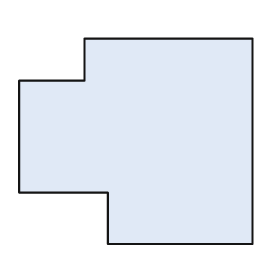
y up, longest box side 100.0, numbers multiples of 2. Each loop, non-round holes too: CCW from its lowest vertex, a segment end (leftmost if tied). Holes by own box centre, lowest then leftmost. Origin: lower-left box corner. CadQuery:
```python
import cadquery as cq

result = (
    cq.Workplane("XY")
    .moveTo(38.0, 0.0)
    .lineTo(100.0, 0.0)
    .lineTo(100.0, 88.0)
    .lineTo(28.0, 88.0)
    .lineTo(28.0, 70.0)
    .lineTo(0.0, 70.0)
    .lineTo(0.0, 22.0)
    .lineTo(38.0, 22.0)
    .close()
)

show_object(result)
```